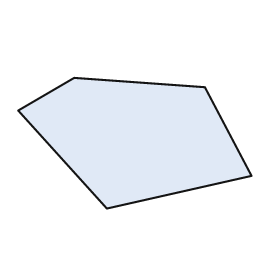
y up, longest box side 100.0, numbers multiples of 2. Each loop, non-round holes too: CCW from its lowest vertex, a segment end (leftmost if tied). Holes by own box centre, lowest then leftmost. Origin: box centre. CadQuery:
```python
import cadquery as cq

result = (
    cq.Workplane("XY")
    .moveTo(-12.0, -28.0)
    .lineTo(50.0, -14.0)
    .lineTo(30.0, 24.0)
    .lineTo(-26.0, 28.0)
    .lineTo(-50.0, 14.0)
    .close()
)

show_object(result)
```